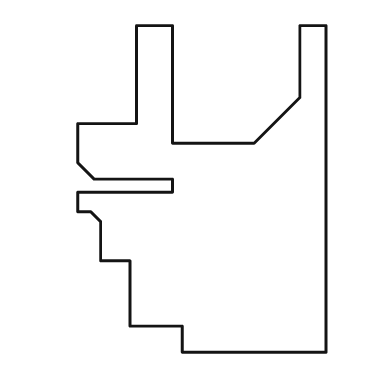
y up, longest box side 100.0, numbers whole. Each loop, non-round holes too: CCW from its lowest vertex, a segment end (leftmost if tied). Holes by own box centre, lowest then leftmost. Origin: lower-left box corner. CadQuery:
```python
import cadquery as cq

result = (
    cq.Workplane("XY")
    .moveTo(32.0, 0.0)
    .lineTo(76.0, 0.0)
    .lineTo(76.0, 100.0)
    .lineTo(68.0, 100.0)
    .lineTo(68.0, 78.0)
    .lineTo(54.0, 64.0)
    .lineTo(29.0, 64.0)
    .lineTo(29.0, 100.0)
    .lineTo(18.0, 100.0)
    .lineTo(18.0, 70.0)
    .lineTo(0.0, 70.0)
    .lineTo(0.0, 58.0)
    .lineTo(5.0, 53.0)
    .lineTo(29.0, 53.0)
    .lineTo(29.0, 49.0)
    .lineTo(0.0, 49.0)
    .lineTo(0.0, 43.0)
    .lineTo(4.0, 43.0)
    .lineTo(7.0, 40.0)
    .lineTo(7.0, 28.0)
    .lineTo(16.0, 28.0)
    .lineTo(16.0, 8.0)
    .lineTo(32.0, 8.0)
    .close()
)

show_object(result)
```